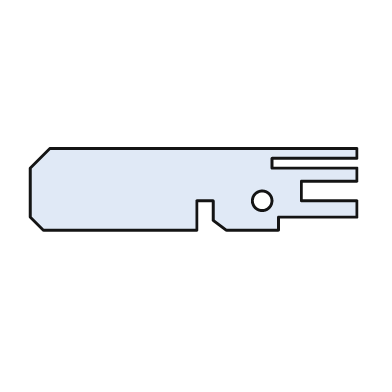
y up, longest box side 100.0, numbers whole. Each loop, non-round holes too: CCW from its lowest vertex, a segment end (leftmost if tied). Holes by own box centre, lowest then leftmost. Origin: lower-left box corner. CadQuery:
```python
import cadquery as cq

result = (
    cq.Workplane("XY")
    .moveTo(4.0, 0.0)
    .lineTo(51.0, 0.0)
    .lineTo(51.0, 9.0)
    .lineTo(56.0, 9.0)
    .lineTo(56.0, 3.0)
    .lineTo(60.0, 0.0)
    .lineTo(76.0, 0.0)
    .lineTo(76.0, 4.0)
    .lineTo(100.0, 4.0)
    .lineTo(100.0, 9.0)
    .lineTo(83.0, 9.0)
    .lineTo(83.0, 15.0)
    .lineTo(100.0, 15.0)
    .lineTo(100.0, 19.0)
    .lineTo(74.0, 19.0)
    .lineTo(74.0, 22.0)
    .lineTo(100.0, 22.0)
    .lineTo(100.0, 25.0)
    .lineTo(6.0, 25.0)
    .lineTo(0.0, 19.0)
    .lineTo(0.0, 4.0)
    .close()
    .moveTo(71.0, 9.0)
    .circle(3.0)
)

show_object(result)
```